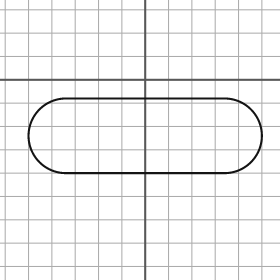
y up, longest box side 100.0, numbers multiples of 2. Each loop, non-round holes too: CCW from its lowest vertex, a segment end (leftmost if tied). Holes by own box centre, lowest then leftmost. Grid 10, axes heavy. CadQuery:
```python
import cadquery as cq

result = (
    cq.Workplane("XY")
    .moveTo(-34.0, -40.0)
    .lineTo(34.0, -40.0)
    .threePointArc((50.0, -24.0), (34.0, -8.0))
    .lineTo(-34.0, -8.0)
    .threePointArc((-50.0, -24.0), (-34.0, -40.0))
    .close()
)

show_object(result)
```